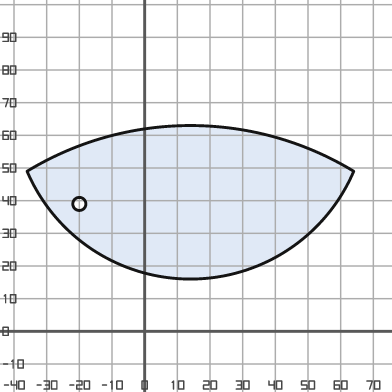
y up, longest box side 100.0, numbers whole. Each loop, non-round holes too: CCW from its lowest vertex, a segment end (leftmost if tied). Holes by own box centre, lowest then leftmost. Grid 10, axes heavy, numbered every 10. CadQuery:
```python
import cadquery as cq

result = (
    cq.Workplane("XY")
    .moveTo(-36.0, 49.0)
    .threePointArc((14.0, 16.0), (64.0, 49.0))
    .threePointArc((14.0, 63.0), (-36.0, 49.0))
    .close()
    .moveTo(-20.0, 39.0)
    .circle(2.0)
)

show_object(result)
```